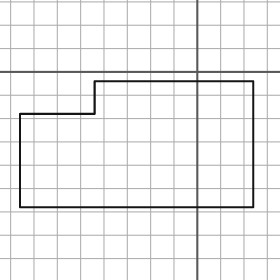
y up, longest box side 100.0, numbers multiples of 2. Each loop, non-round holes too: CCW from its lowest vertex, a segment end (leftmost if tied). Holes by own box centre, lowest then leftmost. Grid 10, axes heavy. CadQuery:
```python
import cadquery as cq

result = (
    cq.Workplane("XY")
    .moveTo(-76.0, -58.0)
    .lineTo(24.0, -58.0)
    .lineTo(24.0, -4.0)
    .lineTo(-44.0, -4.0)
    .lineTo(-44.0, -18.0)
    .lineTo(-76.0, -18.0)
    .close()
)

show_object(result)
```